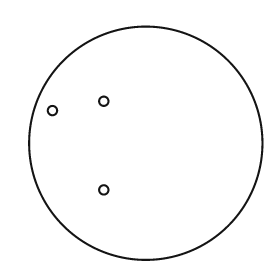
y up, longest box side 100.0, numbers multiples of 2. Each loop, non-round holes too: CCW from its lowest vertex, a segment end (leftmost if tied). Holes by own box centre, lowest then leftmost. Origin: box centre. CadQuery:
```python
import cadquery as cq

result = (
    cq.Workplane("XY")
    .moveTo(0.0, 0.0)
    .circle(50.0)
    .moveTo(-18.0, -20.0)
    .circle(2.0)
    .moveTo(-40.0, 14.0)
    .circle(2.0)
    .moveTo(-18.0, 18.0)
    .circle(2.0)
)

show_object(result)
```